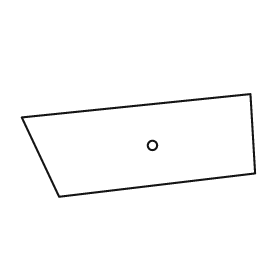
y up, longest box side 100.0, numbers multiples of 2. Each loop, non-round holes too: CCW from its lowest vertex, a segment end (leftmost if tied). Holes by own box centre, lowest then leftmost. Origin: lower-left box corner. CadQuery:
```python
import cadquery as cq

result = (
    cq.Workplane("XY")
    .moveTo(16.0, 0.0)
    .lineTo(100.0, 10.0)
    .lineTo(98.0, 44.0)
    .lineTo(0.0, 34.0)
    .close()
    .moveTo(56.0, 22.0)
    .circle(2.0)
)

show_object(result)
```